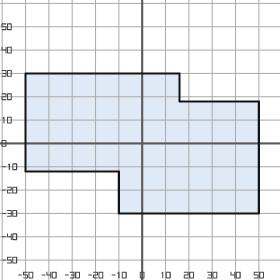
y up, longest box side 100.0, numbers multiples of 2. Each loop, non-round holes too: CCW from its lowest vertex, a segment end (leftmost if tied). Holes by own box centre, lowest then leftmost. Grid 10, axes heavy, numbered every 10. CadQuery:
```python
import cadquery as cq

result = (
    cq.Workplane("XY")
    .moveTo(-10.0, -30.0)
    .lineTo(50.0, -30.0)
    .lineTo(50.0, 18.0)
    .lineTo(16.0, 18.0)
    .lineTo(16.0, 30.0)
    .lineTo(-50.0, 30.0)
    .lineTo(-50.0, -12.0)
    .lineTo(-10.0, -12.0)
    .close()
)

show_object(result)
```